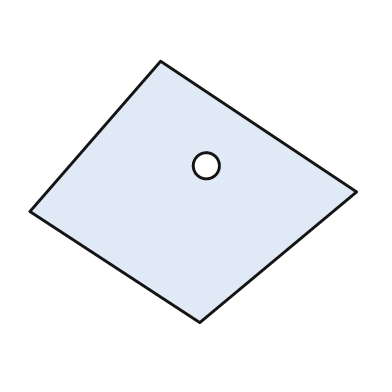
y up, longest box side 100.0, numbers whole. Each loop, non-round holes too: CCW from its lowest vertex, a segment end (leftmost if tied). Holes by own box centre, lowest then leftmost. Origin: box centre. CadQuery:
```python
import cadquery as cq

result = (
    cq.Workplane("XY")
    .moveTo(2.0, -40.0)
    .lineTo(50.0, 0.0)
    .lineTo(-10.0, 40.0)
    .lineTo(-50.0, -6.0)
    .close()
    .moveTo(4.0, 8.0)
    .circle(4.0)
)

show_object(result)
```